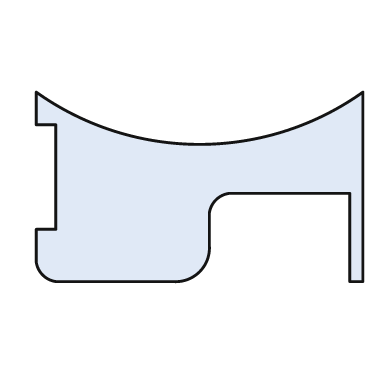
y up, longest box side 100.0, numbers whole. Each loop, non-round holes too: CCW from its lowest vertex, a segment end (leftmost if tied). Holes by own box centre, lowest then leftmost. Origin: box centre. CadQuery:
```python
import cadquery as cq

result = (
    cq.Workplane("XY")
    .moveTo(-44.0, -29.0)
    .lineTo(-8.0, -29.0)
    .threePointArc((0.0, -26.0), (3.0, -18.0))
    .lineTo(3.0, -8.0)
    .threePointArc((5.0, -4.0), (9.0, -2.0))
    .lineTo(46.0, -2.0)
    .lineTo(46.0, -29.0)
    .lineTo(50.0, -29.0)
    .lineTo(50.0, 29.0)
    .threePointArc((0.0, 13.0), (-50.0, 29.0))
    .lineTo(-50.0, 19.0)
    .lineTo(-44.0, 19.0)
    .lineTo(-44.0, -13.0)
    .lineTo(-50.0, -13.0)
    .lineTo(-50.0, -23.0)
    .threePointArc((-48.0, -27.0), (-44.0, -29.0))
    .close()
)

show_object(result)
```